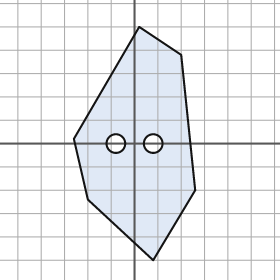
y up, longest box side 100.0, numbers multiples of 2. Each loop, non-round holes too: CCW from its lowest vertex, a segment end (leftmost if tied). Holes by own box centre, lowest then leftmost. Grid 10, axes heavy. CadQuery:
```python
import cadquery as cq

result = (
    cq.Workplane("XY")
    .moveTo(8.0, -50.0)
    .lineTo(26.0, -20.0)
    .lineTo(20.0, 38.0)
    .lineTo(2.0, 50.0)
    .lineTo(-26.0, 2.0)
    .lineTo(-20.0, -24.0)
    .close()
    .moveTo(-8.0, 0.0)
    .circle(4.0)
    .moveTo(8.0, 0.0)
    .circle(4.0)
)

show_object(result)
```